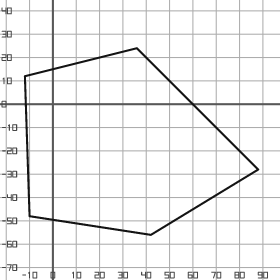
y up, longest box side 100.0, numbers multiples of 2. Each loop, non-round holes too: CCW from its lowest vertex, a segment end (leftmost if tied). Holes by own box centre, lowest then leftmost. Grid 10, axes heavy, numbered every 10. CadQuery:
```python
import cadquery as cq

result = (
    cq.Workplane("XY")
    .moveTo(42.0, -56.0)
    .lineTo(88.0, -28.0)
    .lineTo(36.0, 24.0)
    .lineTo(-12.0, 12.0)
    .lineTo(-10.0, -48.0)
    .close()
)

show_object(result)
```